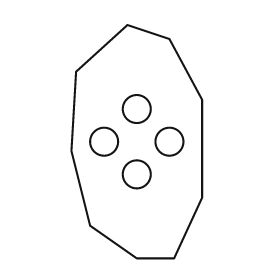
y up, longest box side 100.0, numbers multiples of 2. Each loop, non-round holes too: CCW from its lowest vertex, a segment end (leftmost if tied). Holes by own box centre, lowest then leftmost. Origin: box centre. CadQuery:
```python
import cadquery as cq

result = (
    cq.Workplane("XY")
    .moveTo(0.0, -50.0)
    .lineTo(16.0, -50.0)
    .lineTo(28.0, -24.0)
    .lineTo(28.0, 18.0)
    .lineTo(14.0, 44.0)
    .lineTo(-4.0, 50.0)
    .lineTo(-26.0, 30.0)
    .lineTo(-28.0, -4.0)
    .lineTo(-20.0, -36.0)
    .close()
    .moveTo(0.0, -14.0)
    .circle(6.0)
    .moveTo(-14.0, 0.0)
    .circle(6.0)
    .moveTo(14.0, 0.0)
    .circle(6.0)
    .moveTo(0.0, 14.0)
    .circle(6.0)
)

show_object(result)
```